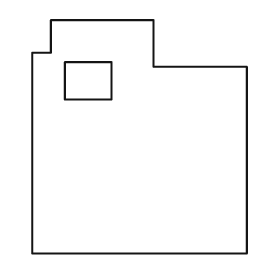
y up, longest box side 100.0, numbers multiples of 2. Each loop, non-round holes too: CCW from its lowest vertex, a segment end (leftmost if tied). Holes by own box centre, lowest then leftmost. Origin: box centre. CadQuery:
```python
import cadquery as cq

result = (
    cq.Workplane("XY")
    .moveTo(-46.0, -50.0)
    .lineTo(46.0, -50.0)
    .lineTo(46.0, 30.0)
    .lineTo(6.0, 30.0)
    .lineTo(6.0, 50.0)
    .lineTo(-38.0, 50.0)
    .lineTo(-38.0, 36.0)
    .lineTo(-46.0, 36.0)
    .close()
    .moveTo(-32.0, 16.0)
    .lineTo(-12.0, 16.0)
    .lineTo(-12.0, 32.0)
    .lineTo(-32.0, 32.0)
    .close()
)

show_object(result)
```